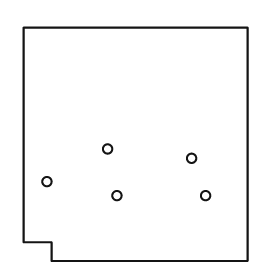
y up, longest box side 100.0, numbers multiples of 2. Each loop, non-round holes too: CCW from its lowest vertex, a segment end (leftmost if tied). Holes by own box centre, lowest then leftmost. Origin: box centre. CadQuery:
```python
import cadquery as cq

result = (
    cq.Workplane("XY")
    .moveTo(-36.0, -50.0)
    .lineTo(48.0, -50.0)
    .lineTo(48.0, 50.0)
    .lineTo(-48.0, 50.0)
    .lineTo(-48.0, -42.0)
    .lineTo(-36.0, -42.0)
    .close()
    .moveTo(-8.0, -22.0)
    .circle(2.0)
    .moveTo(30.0, -22.0)
    .circle(2.0)
    .moveTo(-38.0, -16.0)
    .circle(2.0)
    .moveTo(24.0, -6.0)
    .circle(2.0)
    .moveTo(-12.0, -2.0)
    .circle(2.0)
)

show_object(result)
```